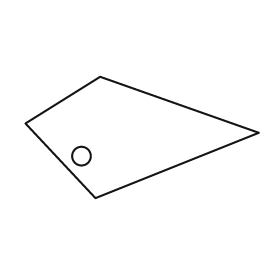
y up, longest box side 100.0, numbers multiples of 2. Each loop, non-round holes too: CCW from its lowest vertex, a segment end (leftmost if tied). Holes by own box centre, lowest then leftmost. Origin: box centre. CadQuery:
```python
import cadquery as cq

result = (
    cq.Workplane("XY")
    .moveTo(-20.0, -26.0)
    .lineTo(50.0, 2.0)
    .lineTo(-18.0, 26.0)
    .lineTo(-50.0, 6.0)
    .close()
    .moveTo(-26.0, -8.0)
    .circle(4.0)
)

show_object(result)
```